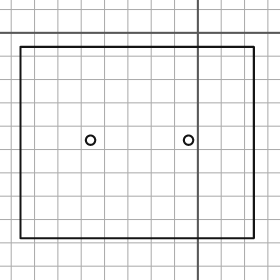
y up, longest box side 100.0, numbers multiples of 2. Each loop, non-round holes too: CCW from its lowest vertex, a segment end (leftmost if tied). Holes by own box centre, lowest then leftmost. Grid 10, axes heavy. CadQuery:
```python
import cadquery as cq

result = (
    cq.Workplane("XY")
    .moveTo(-76.0, -88.0)
    .lineTo(24.0, -88.0)
    .lineTo(24.0, -6.0)
    .lineTo(-76.0, -6.0)
    .close()
    .moveTo(-46.0, -46.0)
    .circle(2.0)
    .moveTo(-4.0, -46.0)
    .circle(2.0)
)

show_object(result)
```